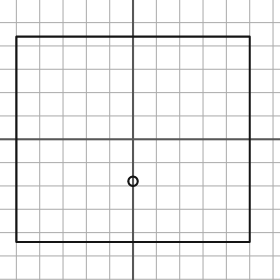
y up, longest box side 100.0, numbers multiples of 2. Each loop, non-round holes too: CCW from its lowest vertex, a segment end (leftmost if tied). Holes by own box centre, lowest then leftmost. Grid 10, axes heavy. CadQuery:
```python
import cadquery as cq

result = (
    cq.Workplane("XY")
    .moveTo(-50.0, -44.0)
    .lineTo(50.0, -44.0)
    .lineTo(50.0, 44.0)
    .lineTo(-50.0, 44.0)
    .close()
    .moveTo(0.0, -18.0)
    .circle(2.0)
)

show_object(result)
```